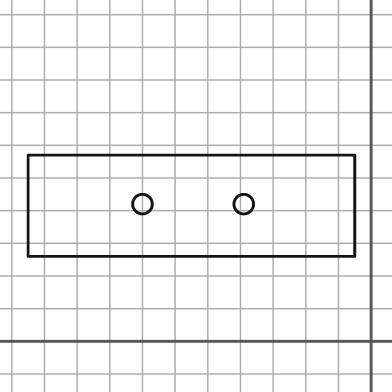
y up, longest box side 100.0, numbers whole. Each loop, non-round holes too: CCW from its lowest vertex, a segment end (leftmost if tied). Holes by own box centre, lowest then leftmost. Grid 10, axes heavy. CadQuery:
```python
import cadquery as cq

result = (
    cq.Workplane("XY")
    .moveTo(-105.0, 26.0)
    .lineTo(-5.0, 26.0)
    .lineTo(-5.0, 57.0)
    .lineTo(-105.0, 57.0)
    .close()
    .moveTo(-70.0, 42.0)
    .circle(3.0)
    .moveTo(-39.0, 42.0)
    .circle(3.0)
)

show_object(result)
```